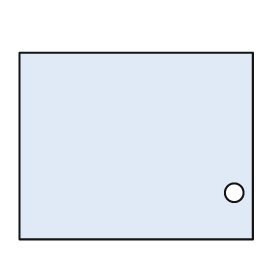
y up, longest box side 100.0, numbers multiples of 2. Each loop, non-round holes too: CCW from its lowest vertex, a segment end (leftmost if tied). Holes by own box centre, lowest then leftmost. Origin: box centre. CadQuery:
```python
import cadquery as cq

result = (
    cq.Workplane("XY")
    .moveTo(-50.0, -40.0)
    .lineTo(50.0, -40.0)
    .lineTo(50.0, 40.0)
    .lineTo(-50.0, 40.0)
    .close()
    .moveTo(42.0, -20.0)
    .circle(4.0)
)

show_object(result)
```